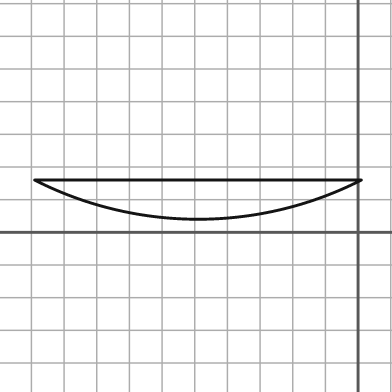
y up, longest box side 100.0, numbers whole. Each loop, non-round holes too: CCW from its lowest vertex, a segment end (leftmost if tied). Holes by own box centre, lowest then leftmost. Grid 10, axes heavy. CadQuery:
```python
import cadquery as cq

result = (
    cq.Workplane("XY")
    .moveTo(-99.0, 16.0)
    .threePointArc((-49.0, 4.0), (1.0, 16.0))
    .close()
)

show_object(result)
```